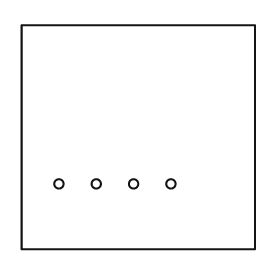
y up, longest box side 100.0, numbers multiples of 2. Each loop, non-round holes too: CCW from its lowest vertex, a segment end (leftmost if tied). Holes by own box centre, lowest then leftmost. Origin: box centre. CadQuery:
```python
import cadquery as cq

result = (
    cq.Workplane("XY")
    .moveTo(-50.0, -48.0)
    .lineTo(50.0, -48.0)
    .lineTo(50.0, 48.0)
    .lineTo(-50.0, 48.0)
    .close()
    .moveTo(-34.0, -20.0)
    .circle(2.0)
    .moveTo(-18.0, -20.0)
    .circle(2.0)
    .moveTo(-2.0, -20.0)
    .circle(2.0)
    .moveTo(14.0, -20.0)
    .circle(2.0)
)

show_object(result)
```